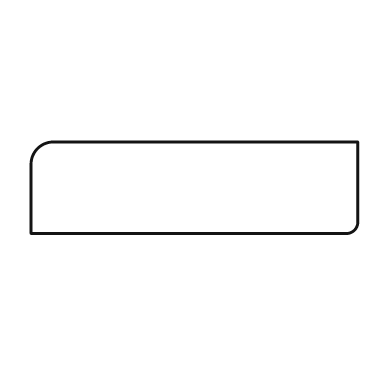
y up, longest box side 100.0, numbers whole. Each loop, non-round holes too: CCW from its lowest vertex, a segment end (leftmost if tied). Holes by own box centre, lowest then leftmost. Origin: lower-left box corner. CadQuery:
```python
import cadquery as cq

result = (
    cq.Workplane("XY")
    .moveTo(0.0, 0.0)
    .lineTo(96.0, 0.0)
    .threePointArc((99.0, 1.0), (100.0, 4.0))
    .lineTo(100.0, 28.0)
    .lineTo(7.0, 28.0)
    .threePointArc((2.0, 26.0), (0.0, 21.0))
    .close()
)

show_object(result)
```